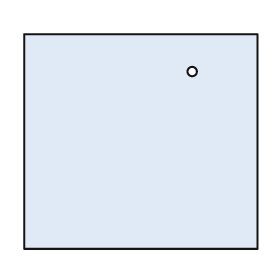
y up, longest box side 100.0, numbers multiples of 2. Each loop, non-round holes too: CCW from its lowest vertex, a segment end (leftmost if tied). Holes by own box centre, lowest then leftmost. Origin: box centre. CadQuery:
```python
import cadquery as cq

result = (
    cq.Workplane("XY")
    .moveTo(-50.0, -46.0)
    .lineTo(50.0, -46.0)
    .lineTo(50.0, 46.0)
    .lineTo(-50.0, 46.0)
    .close()
    .moveTo(22.0, 30.0)
    .circle(2.0)
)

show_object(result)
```